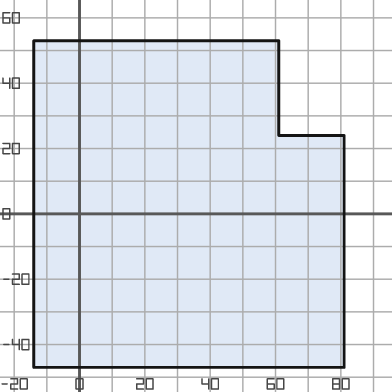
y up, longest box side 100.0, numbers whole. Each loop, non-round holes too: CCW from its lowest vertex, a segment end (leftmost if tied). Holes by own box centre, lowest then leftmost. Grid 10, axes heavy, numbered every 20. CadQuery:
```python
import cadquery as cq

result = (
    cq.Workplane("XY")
    .moveTo(-14.0, -47.0)
    .lineTo(81.0, -47.0)
    .lineTo(81.0, 24.0)
    .lineTo(61.0, 24.0)
    .lineTo(61.0, 53.0)
    .lineTo(-14.0, 53.0)
    .close()
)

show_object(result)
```